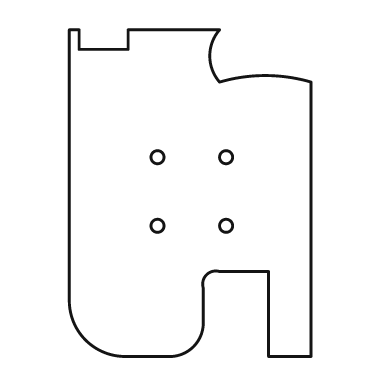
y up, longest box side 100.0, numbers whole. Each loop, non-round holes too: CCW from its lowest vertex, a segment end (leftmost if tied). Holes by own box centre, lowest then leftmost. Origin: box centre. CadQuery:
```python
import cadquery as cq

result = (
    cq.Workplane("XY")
    .moveTo(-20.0, -50.0)
    .lineTo(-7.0, -50.0)
    .threePointArc((1.0, -47.0), (4.0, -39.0))
    .lineTo(4.0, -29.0)
    .threePointArc((5.0, -25.0), (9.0, -24.0))
    .lineTo(24.0, -24.0)
    .lineTo(24.0, -50.0)
    .lineTo(37.0, -50.0)
    .lineTo(37.0, 34.0)
    .threePointArc((23.0, 36.0), (9.0, 34.0))
    .threePointArc((6.0, 42.0), (9.0, 50.0))
    .lineTo(-19.0, 50.0)
    .lineTo(-19.0, 44.0)
    .lineTo(-34.0, 44.0)
    .lineTo(-34.0, 50.0)
    .lineTo(-37.0, 50.0)
    .lineTo(-37.0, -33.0)
    .threePointArc((-32.0, -45.0), (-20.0, -50.0))
    .close()
    .moveTo(-10.0, -10.0)
    .circle(2.0)
    .moveTo(11.0, -10.0)
    .circle(2.0)
    .moveTo(-10.0, 11.0)
    .circle(2.0)
    .moveTo(11.0, 11.0)
    .circle(2.0)
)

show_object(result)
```